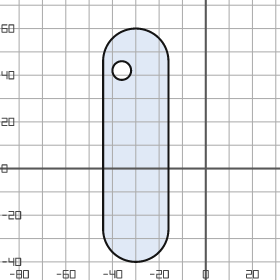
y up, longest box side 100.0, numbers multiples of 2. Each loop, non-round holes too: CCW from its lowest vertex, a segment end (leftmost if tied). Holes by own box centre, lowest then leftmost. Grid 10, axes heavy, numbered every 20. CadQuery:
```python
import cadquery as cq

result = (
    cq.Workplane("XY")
    .moveTo(-44.0, -26.0)
    .threePointArc((-30.0, -40.0), (-16.0, -26.0))
    .lineTo(-16.0, 46.0)
    .threePointArc((-30.0, 60.0), (-44.0, 46.0))
    .close()
    .moveTo(-36.0, 42.0)
    .circle(4.0)
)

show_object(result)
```